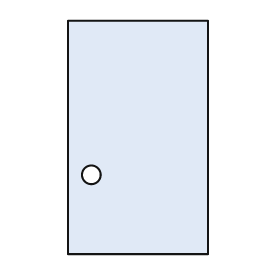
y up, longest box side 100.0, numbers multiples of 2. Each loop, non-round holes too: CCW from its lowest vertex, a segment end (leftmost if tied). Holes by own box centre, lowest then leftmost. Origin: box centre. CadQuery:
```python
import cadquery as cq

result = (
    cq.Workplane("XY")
    .moveTo(-30.0, -50.0)
    .lineTo(30.0, -50.0)
    .lineTo(30.0, 50.0)
    .lineTo(-30.0, 50.0)
    .close()
    .moveTo(-20.0, -16.0)
    .circle(4.0)
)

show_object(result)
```